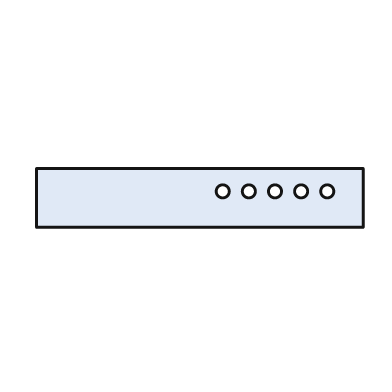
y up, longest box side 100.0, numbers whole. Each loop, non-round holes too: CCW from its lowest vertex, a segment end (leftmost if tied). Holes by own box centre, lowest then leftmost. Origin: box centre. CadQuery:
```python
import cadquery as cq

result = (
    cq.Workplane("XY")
    .moveTo(-50.0, -9.0)
    .lineTo(50.0, -9.0)
    .lineTo(50.0, 9.0)
    .lineTo(-50.0, 9.0)
    .close()
    .moveTo(7.0, 2.0)
    .circle(2.0)
    .moveTo(15.0, 2.0)
    .circle(2.0)
    .moveTo(23.0, 2.0)
    .circle(2.0)
    .moveTo(31.0, 2.0)
    .circle(2.0)
    .moveTo(39.0, 2.0)
    .circle(2.0)
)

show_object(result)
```